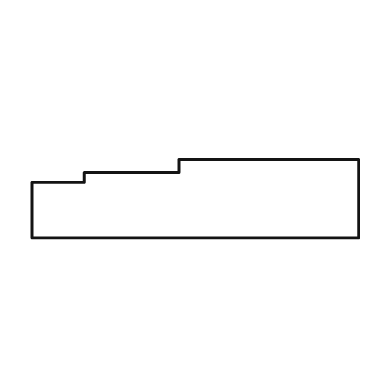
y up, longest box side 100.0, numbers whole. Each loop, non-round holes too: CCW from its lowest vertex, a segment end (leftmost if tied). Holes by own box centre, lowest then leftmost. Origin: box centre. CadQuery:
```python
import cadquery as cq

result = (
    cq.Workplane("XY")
    .moveTo(-50.0, -12.0)
    .lineTo(50.0, -12.0)
    .lineTo(50.0, 12.0)
    .lineTo(-5.0, 12.0)
    .lineTo(-5.0, 8.0)
    .lineTo(-34.0, 8.0)
    .lineTo(-34.0, 5.0)
    .lineTo(-50.0, 5.0)
    .close()
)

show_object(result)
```